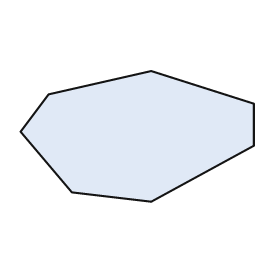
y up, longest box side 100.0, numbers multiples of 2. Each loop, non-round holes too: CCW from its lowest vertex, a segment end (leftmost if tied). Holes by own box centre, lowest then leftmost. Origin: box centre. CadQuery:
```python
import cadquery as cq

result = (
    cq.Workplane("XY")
    .moveTo(6.0, -28.0)
    .lineTo(50.0, -4.0)
    .lineTo(50.0, 14.0)
    .lineTo(6.0, 28.0)
    .lineTo(-38.0, 18.0)
    .lineTo(-50.0, 2.0)
    .lineTo(-28.0, -24.0)
    .close()
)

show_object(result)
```